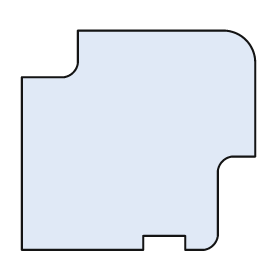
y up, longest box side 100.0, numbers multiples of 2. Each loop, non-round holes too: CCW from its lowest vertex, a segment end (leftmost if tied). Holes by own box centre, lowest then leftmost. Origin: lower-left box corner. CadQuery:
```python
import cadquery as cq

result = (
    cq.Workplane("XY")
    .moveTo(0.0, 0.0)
    .lineTo(52.0, 0.0)
    .lineTo(52.0, 6.0)
    .lineTo(70.0, 6.0)
    .lineTo(70.0, 0.0)
    .lineTo(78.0, 0.0)
    .threePointArc((82.0, 2.0), (84.0, 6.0))
    .lineTo(84.0, 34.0)
    .threePointArc((86.0, 38.0), (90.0, 40.0))
    .lineTo(100.0, 40.0)
    .lineTo(100.0, 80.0)
    .threePointArc((96.0, 90.0), (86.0, 94.0))
    .lineTo(24.0, 94.0)
    .lineTo(24.0, 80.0)
    .threePointArc((22.0, 76.0), (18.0, 74.0))
    .lineTo(0.0, 74.0)
    .close()
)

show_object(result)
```